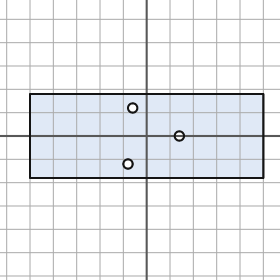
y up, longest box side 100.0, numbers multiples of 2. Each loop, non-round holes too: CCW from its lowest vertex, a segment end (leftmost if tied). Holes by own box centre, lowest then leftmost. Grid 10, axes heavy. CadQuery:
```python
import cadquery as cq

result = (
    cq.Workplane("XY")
    .moveTo(-50.0, -18.0)
    .lineTo(50.0, -18.0)
    .lineTo(50.0, 18.0)
    .lineTo(-50.0, 18.0)
    .close()
    .moveTo(-8.0, -12.0)
    .circle(2.0)
    .moveTo(14.0, 0.0)
    .circle(2.0)
    .moveTo(-6.0, 12.0)
    .circle(2.0)
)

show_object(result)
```